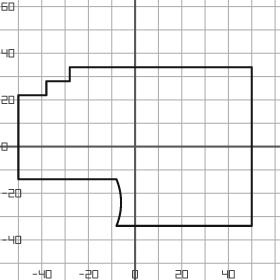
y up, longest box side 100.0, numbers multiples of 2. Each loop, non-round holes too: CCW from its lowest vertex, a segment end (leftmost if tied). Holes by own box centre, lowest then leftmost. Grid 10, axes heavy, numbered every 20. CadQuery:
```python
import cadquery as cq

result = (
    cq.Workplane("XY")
    .moveTo(-8.0, -34.0)
    .lineTo(50.0, -34.0)
    .lineTo(50.0, 34.0)
    .lineTo(-28.0, 34.0)
    .lineTo(-28.0, 28.0)
    .lineTo(-38.0, 28.0)
    .lineTo(-38.0, 22.0)
    .lineTo(-50.0, 22.0)
    .lineTo(-50.0, -14.0)
    .lineTo(-8.0, -14.0)
    .threePointArc((-6.0, -24.0), (-8.0, -34.0))
    .close()
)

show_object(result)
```